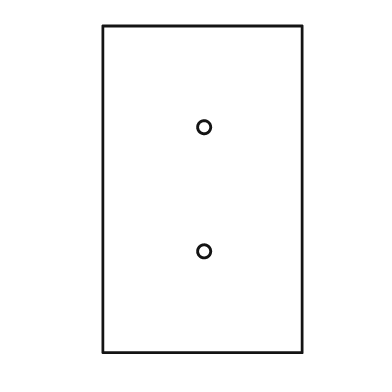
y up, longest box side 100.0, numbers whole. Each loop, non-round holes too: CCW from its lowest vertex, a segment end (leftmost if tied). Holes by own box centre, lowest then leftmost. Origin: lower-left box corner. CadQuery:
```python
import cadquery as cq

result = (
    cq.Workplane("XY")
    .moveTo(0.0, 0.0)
    .lineTo(61.0, 0.0)
    .lineTo(61.0, 100.0)
    .lineTo(0.0, 100.0)
    .close()
    .moveTo(31.0, 31.0)
    .circle(2.0)
    .moveTo(31.0, 69.0)
    .circle(2.0)
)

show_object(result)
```